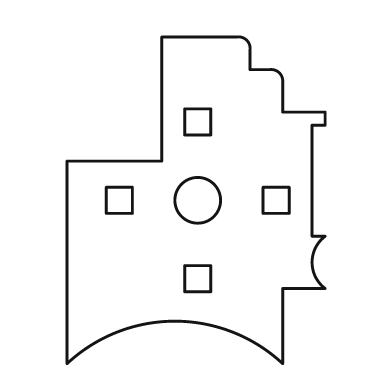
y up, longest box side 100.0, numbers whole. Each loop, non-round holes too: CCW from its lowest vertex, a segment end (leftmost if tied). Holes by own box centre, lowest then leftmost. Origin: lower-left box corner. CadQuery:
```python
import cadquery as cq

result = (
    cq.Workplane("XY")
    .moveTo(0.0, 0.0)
    .threePointArc((33.0, 13.0), (66.0, 0.0))
    .lineTo(66.0, 23.0)
    .lineTo(79.0, 23.0)
    .threePointArc((75.0, 31.0), (79.0, 39.0))
    .lineTo(75.0, 39.0)
    .lineTo(75.0, 73.0)
    .lineTo(79.0, 73.0)
    .lineTo(79.0, 77.0)
    .lineTo(66.0, 77.0)
    .lineTo(66.0, 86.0)
    .threePointArc((65.0, 89.0), (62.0, 90.0))
    .lineTo(56.0, 90.0)
    .lineTo(56.0, 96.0)
    .threePointArc((55.0, 99.0), (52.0, 100.0))
    .lineTo(29.0, 100.0)
    .lineTo(29.0, 62.0)
    .lineTo(0.0, 62.0)
    .close()
    .moveTo(36.0, 22.0)
    .lineTo(44.0, 22.0)
    .lineTo(44.0, 30.0)
    .lineTo(36.0, 30.0)
    .close()
    .moveTo(12.0, 46.0)
    .lineTo(20.0, 46.0)
    .lineTo(20.0, 54.0)
    .lineTo(12.0, 54.0)
    .close()
    .moveTo(40.0, 50.0)
    .circle(7.0)
    .moveTo(60.0, 46.0)
    .lineTo(68.0, 46.0)
    .lineTo(68.0, 54.0)
    .lineTo(60.0, 54.0)
    .close()
    .moveTo(36.0, 70.0)
    .lineTo(44.0, 70.0)
    .lineTo(44.0, 78.0)
    .lineTo(36.0, 78.0)
    .close()
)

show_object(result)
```